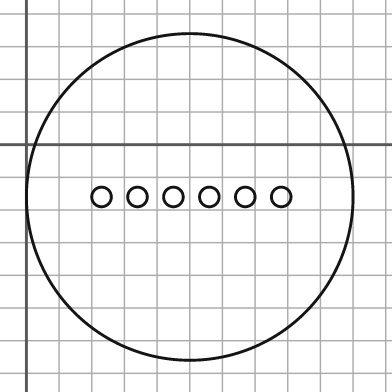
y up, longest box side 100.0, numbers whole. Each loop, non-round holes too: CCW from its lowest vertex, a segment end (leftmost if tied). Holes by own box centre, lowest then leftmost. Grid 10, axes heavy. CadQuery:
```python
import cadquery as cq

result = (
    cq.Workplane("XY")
    .moveTo(50.0, -16.0)
    .circle(50.0)
    .moveTo(23.0, -16.0)
    .circle(3.0)
    .moveTo(34.0, -16.0)
    .circle(3.0)
    .moveTo(45.0, -16.0)
    .circle(3.0)
    .moveTo(56.0, -16.0)
    .circle(3.0)
    .moveTo(67.0, -16.0)
    .circle(3.0)
    .moveTo(78.0, -16.0)
    .circle(3.0)
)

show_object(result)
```